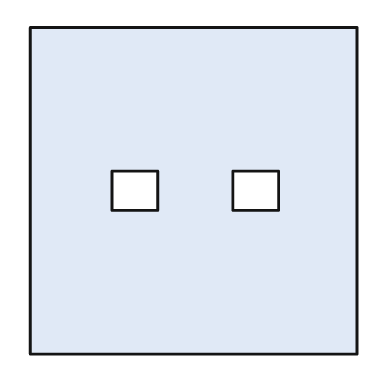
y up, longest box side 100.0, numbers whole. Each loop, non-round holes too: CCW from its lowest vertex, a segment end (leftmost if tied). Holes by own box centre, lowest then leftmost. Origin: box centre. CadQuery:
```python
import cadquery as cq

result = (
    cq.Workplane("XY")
    .moveTo(-50.0, -50.0)
    .lineTo(50.0, -50.0)
    .lineTo(50.0, 50.0)
    .lineTo(-50.0, 50.0)
    .close()
    .moveTo(-25.0, -6.0)
    .lineTo(-11.0, -6.0)
    .lineTo(-11.0, 6.0)
    .lineTo(-25.0, 6.0)
    .close()
    .moveTo(12.0, -6.0)
    .lineTo(26.0, -6.0)
    .lineTo(26.0, 6.0)
    .lineTo(12.0, 6.0)
    .close()
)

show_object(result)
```